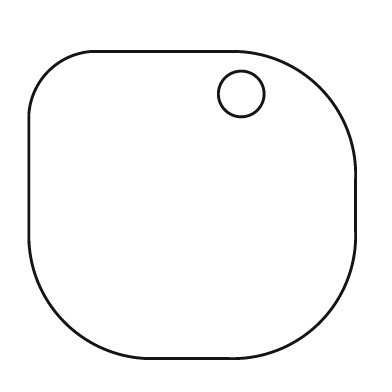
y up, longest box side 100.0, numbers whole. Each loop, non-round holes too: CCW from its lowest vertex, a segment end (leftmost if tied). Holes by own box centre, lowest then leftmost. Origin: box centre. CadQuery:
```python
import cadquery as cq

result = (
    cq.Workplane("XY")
    .moveTo(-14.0, -47.0)
    .lineTo(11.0, -47.0)
    .threePointArc((39.0, -36.0), (50.0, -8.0))
    .lineTo(50.0, 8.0)
    .threePointArc((39.0, 36.0), (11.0, 47.0))
    .lineTo(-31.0, 47.0)
    .threePointArc((-44.0, 41.0), (-50.0, 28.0))
    .lineTo(-50.0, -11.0)
    .threePointArc((-39.0, -36.0), (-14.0, -47.0))
    .close()
    .moveTo(15.0, 34.0)
    .circle(7.0)
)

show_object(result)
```